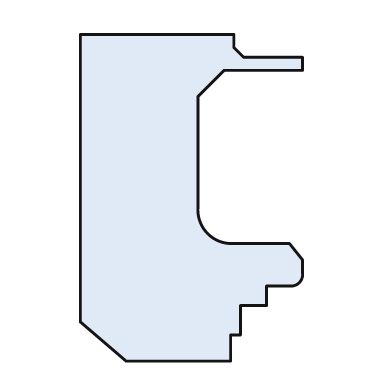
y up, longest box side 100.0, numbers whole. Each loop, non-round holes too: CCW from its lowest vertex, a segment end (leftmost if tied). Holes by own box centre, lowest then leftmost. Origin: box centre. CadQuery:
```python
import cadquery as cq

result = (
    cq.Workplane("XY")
    .moveTo(-20.0, -50.0)
    .lineTo(12.0, -50.0)
    .lineTo(12.0, -42.0)
    .lineTo(15.0, -42.0)
    .lineTo(15.0, -33.0)
    .lineTo(23.0, -33.0)
    .lineTo(23.0, -27.0)
    .lineTo(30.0, -27.0)
    .threePointArc((33.0, -26.0), (34.0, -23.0))
    .lineTo(34.0, -19.0)
    .lineTo(30.0, -14.0)
    .lineTo(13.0, -14.0)
    .threePointArc((5.0, -11.0), (2.0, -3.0))
    .lineTo(2.0, 31.0)
    .lineTo(10.0, 39.0)
    .lineTo(34.0, 39.0)
    .lineTo(34.0, 43.0)
    .lineTo(16.0, 43.0)
    .lineTo(13.0, 46.0)
    .lineTo(13.0, 50.0)
    .lineTo(-34.0, 50.0)
    .lineTo(-34.0, -38.0)
    .close()
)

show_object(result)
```